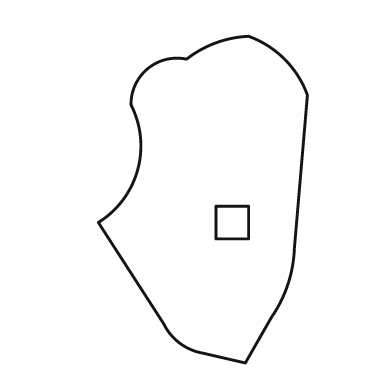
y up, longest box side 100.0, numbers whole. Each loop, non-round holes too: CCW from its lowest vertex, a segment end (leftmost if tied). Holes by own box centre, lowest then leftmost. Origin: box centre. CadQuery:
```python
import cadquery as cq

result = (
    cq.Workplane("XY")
    .moveTo(13.0, -50.0)
    .lineTo(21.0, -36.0)
    .threePointArc((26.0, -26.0), (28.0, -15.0))
    .lineTo(32.0, 32.0)
    .threePointArc((25.0, 43.0), (14.0, 50.0))
    .threePointArc((4.0, 48.0), (-5.0, 43.0))
    .threePointArc((-17.0, 40.0), (-22.0, 29.0))
    .threePointArc((-20.0, 9.0), (-32.0, -7.0))
    .lineTo(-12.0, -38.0)
    .threePointArc((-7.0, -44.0), (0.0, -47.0))
    .close()
    .moveTo(4.0, -12.0)
    .lineTo(14.0, -12.0)
    .lineTo(14.0, -2.0)
    .lineTo(4.0, -2.0)
    .close()
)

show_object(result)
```